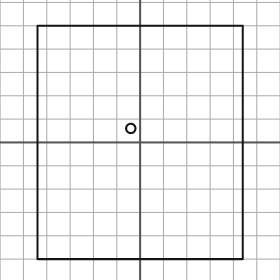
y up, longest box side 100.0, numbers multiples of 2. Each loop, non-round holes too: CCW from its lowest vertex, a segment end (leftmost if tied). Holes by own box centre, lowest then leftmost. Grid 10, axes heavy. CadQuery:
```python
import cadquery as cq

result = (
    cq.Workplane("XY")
    .moveTo(-44.0, -50.0)
    .lineTo(44.0, -50.0)
    .lineTo(44.0, 50.0)
    .lineTo(-44.0, 50.0)
    .close()
    .moveTo(-4.0, 6.0)
    .circle(2.0)
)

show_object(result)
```